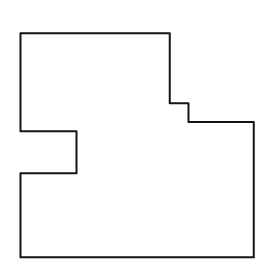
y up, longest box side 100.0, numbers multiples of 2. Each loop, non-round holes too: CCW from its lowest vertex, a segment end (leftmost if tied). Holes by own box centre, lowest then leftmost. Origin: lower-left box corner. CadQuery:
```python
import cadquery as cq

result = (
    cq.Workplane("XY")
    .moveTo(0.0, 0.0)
    .lineTo(100.0, 0.0)
    .lineTo(100.0, 58.0)
    .lineTo(72.0, 58.0)
    .lineTo(72.0, 66.0)
    .lineTo(64.0, 66.0)
    .lineTo(64.0, 96.0)
    .lineTo(0.0, 96.0)
    .lineTo(0.0, 54.0)
    .lineTo(24.0, 54.0)
    .lineTo(24.0, 36.0)
    .lineTo(0.0, 36.0)
    .close()
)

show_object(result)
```